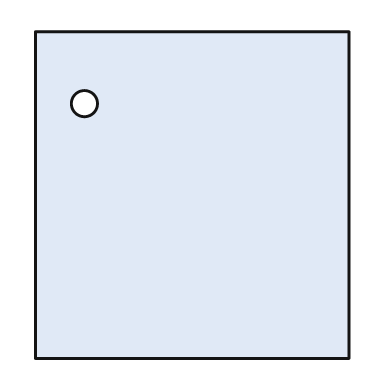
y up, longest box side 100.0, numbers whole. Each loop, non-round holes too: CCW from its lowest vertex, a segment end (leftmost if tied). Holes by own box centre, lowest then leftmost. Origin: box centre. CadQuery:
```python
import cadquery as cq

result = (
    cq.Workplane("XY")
    .moveTo(-48.0, -50.0)
    .lineTo(48.0, -50.0)
    .lineTo(48.0, 50.0)
    .lineTo(-48.0, 50.0)
    .close()
    .moveTo(-33.0, 28.0)
    .circle(4.0)
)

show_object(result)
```